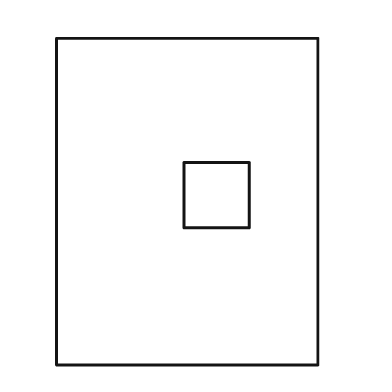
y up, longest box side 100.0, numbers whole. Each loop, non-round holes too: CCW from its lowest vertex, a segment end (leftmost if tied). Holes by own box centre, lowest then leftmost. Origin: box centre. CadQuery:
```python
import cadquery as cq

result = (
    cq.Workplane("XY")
    .moveTo(-40.0, -50.0)
    .lineTo(40.0, -50.0)
    .lineTo(40.0, 50.0)
    .lineTo(-40.0, 50.0)
    .close()
    .moveTo(-1.0, -8.0)
    .lineTo(19.0, -8.0)
    .lineTo(19.0, 12.0)
    .lineTo(-1.0, 12.0)
    .close()
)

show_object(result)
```